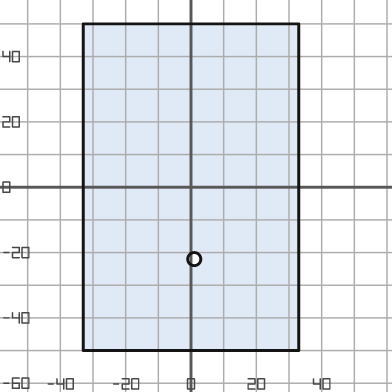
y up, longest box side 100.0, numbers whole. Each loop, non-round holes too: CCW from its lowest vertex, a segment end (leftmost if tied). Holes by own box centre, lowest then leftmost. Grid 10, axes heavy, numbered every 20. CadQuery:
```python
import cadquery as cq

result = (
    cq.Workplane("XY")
    .moveTo(-33.0, -50.0)
    .lineTo(33.0, -50.0)
    .lineTo(33.0, 50.0)
    .lineTo(-33.0, 50.0)
    .close()
    .moveTo(1.0, -22.0)
    .circle(2.0)
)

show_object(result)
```